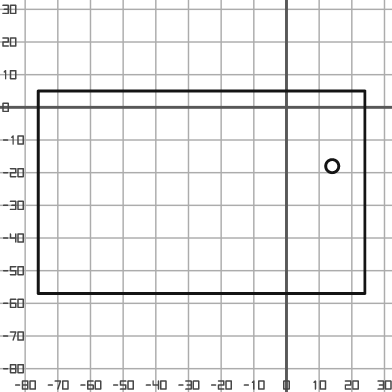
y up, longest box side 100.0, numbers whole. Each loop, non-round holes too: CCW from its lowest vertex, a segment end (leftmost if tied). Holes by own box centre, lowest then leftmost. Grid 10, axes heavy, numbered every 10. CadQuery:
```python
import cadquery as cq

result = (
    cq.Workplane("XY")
    .moveTo(-76.0, -57.0)
    .lineTo(24.0, -57.0)
    .lineTo(24.0, 5.0)
    .lineTo(-76.0, 5.0)
    .close()
    .moveTo(14.0, -18.0)
    .circle(2.0)
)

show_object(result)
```